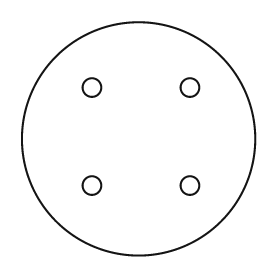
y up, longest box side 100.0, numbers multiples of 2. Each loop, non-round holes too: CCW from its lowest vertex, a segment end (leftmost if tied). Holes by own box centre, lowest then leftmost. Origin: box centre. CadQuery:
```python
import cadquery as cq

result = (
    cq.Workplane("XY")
    .moveTo(0.0, 0.0)
    .circle(50.0)
    .moveTo(-20.0, -20.0)
    .circle(4.0)
    .moveTo(22.0, -20.0)
    .circle(4.0)
    .moveTo(-20.0, 22.0)
    .circle(4.0)
    .moveTo(22.0, 22.0)
    .circle(4.0)
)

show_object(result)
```